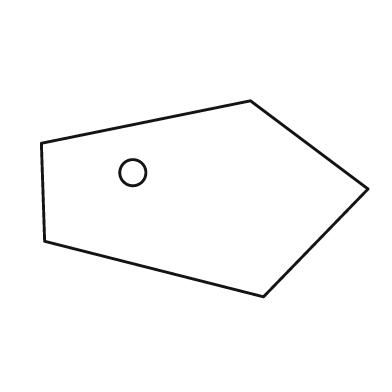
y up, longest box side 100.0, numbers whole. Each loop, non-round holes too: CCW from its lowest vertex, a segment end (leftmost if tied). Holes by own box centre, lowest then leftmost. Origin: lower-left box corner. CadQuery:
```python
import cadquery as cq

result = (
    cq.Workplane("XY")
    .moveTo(68.0, 0.0)
    .lineTo(100.0, 33.0)
    .lineTo(64.0, 60.0)
    .lineTo(0.0, 47.0)
    .lineTo(1.0, 17.0)
    .close()
    .moveTo(28.0, 38.0)
    .circle(4.0)
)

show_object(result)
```